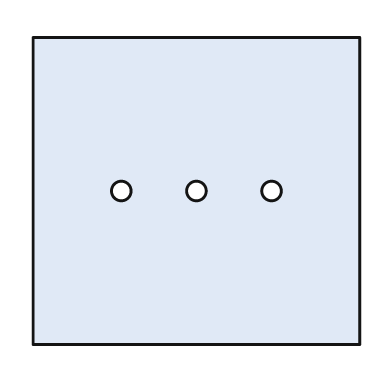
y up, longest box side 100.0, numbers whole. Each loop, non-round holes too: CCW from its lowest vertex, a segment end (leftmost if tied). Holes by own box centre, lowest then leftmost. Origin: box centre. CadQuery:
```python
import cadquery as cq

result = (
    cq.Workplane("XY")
    .moveTo(-50.0, -47.0)
    .lineTo(50.0, -47.0)
    .lineTo(50.0, 47.0)
    .lineTo(-50.0, 47.0)
    .close()
    .moveTo(-23.0, 0.0)
    .circle(3.0)
    .moveTo(0.0, 0.0)
    .circle(3.0)
    .moveTo(23.0, 0.0)
    .circle(3.0)
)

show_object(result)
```